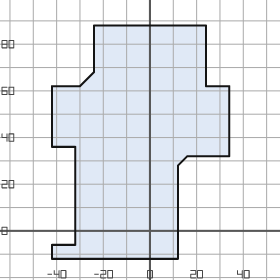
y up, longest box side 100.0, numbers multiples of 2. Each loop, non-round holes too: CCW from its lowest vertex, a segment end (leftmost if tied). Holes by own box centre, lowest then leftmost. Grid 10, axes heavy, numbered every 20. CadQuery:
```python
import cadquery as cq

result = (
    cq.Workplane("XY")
    .moveTo(-42.0, -12.0)
    .lineTo(12.0, -12.0)
    .lineTo(12.0, 28.0)
    .lineTo(16.0, 32.0)
    .lineTo(34.0, 32.0)
    .lineTo(34.0, 62.0)
    .lineTo(24.0, 62.0)
    .lineTo(24.0, 88.0)
    .lineTo(-24.0, 88.0)
    .lineTo(-24.0, 68.0)
    .lineTo(-30.0, 62.0)
    .lineTo(-42.0, 62.0)
    .lineTo(-42.0, 36.0)
    .lineTo(-32.0, 36.0)
    .lineTo(-32.0, -6.0)
    .lineTo(-42.0, -6.0)
    .close()
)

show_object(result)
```